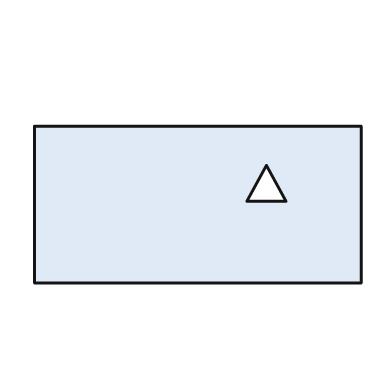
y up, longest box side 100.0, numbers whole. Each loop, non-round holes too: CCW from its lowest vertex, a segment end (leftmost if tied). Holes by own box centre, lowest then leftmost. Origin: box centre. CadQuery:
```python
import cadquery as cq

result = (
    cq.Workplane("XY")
    .moveTo(-50.0, -24.0)
    .lineTo(50.0, -24.0)
    .lineTo(50.0, 24.0)
    .lineTo(-50.0, 24.0)
    .close()
    .moveTo(15.0, 1.0)
    .lineTo(27.0, 1.0)
    .lineTo(21.0, 12.0)
    .close()
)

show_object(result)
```